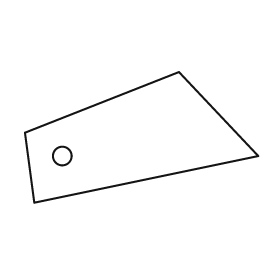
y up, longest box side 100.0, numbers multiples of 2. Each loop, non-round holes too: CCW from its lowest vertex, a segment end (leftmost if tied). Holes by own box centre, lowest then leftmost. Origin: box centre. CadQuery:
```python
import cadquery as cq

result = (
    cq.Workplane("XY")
    .moveTo(-46.0, -28.0)
    .lineTo(50.0, -8.0)
    .lineTo(16.0, 28.0)
    .lineTo(-50.0, 2.0)
    .close()
    .moveTo(-34.0, -8.0)
    .circle(4.0)
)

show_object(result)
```